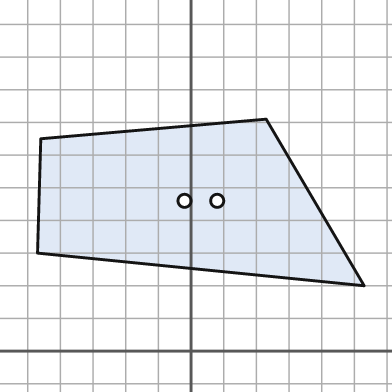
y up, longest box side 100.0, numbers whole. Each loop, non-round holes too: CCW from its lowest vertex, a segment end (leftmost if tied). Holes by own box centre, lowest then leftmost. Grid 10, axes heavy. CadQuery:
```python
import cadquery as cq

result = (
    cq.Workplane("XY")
    .moveTo(53.0, 20.0)
    .lineTo(23.0, 71.0)
    .lineTo(-46.0, 65.0)
    .lineTo(-47.0, 30.0)
    .close()
    .moveTo(-2.0, 46.0)
    .circle(2.0)
    .moveTo(8.0, 46.0)
    .circle(2.0)
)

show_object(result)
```